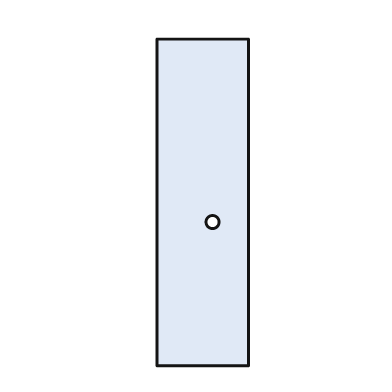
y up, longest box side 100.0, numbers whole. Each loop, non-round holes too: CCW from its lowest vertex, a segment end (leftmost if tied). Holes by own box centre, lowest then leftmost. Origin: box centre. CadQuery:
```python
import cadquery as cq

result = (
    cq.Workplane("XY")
    .moveTo(-14.0, -50.0)
    .lineTo(14.0, -50.0)
    .lineTo(14.0, 50.0)
    .lineTo(-14.0, 50.0)
    .close()
    .moveTo(3.0, -6.0)
    .circle(2.0)
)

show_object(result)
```